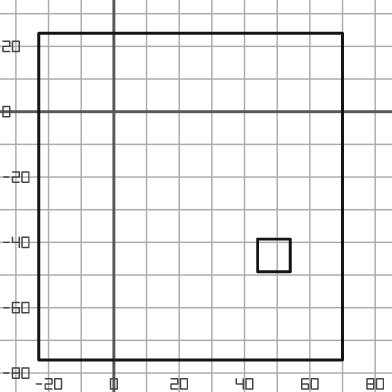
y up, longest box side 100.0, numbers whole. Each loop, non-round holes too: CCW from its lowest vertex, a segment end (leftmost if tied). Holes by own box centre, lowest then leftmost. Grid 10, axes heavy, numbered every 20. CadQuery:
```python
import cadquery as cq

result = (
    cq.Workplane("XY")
    .moveTo(-23.0, -76.0)
    .lineTo(70.0, -76.0)
    .lineTo(70.0, 24.0)
    .lineTo(-23.0, 24.0)
    .close()
    .moveTo(44.0, -49.0)
    .lineTo(54.0, -49.0)
    .lineTo(54.0, -39.0)
    .lineTo(44.0, -39.0)
    .close()
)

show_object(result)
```